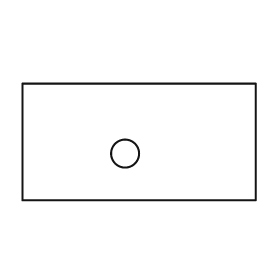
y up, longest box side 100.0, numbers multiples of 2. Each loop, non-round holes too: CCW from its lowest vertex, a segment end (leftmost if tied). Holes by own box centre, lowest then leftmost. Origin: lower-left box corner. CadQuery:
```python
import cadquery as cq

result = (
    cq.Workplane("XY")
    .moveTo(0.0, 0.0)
    .lineTo(100.0, 0.0)
    .lineTo(100.0, 50.0)
    .lineTo(0.0, 50.0)
    .close()
    .moveTo(44.0, 20.0)
    .circle(6.0)
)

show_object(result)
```